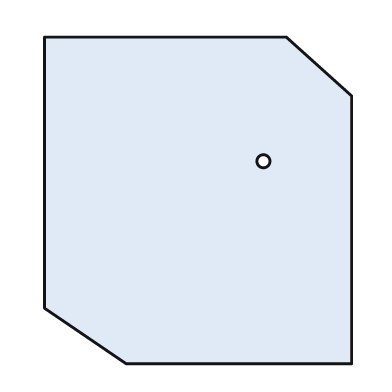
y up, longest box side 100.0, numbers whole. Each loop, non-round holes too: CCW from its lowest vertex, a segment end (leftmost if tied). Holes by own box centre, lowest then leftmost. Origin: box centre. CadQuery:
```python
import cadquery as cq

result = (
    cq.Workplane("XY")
    .moveTo(-22.0, -50.0)
    .lineTo(47.0, -50.0)
    .lineTo(47.0, 32.0)
    .lineTo(27.0, 50.0)
    .lineTo(-47.0, 50.0)
    .lineTo(-47.0, -33.0)
    .close()
    .moveTo(20.0, 12.0)
    .circle(2.0)
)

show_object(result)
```